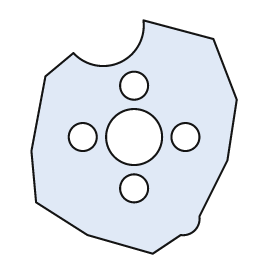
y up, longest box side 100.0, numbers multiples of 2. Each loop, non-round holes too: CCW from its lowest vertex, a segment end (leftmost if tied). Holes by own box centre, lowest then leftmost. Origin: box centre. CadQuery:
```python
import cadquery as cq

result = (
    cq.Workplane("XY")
    .moveTo(8.0, -50.0)
    .lineTo(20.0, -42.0)
    .threePointArc((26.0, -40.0), (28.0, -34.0))
    .lineTo(40.0, -10.0)
    .lineTo(44.0, 16.0)
    .lineTo(34.0, 42.0)
    .lineTo(4.0, 50.0)
    .threePointArc((-6.0, 32.0), (-26.0, 36.0))
    .lineTo(-38.0, 26.0)
    .lineTo(-44.0, -6.0)
    .lineTo(-42.0, -28.0)
    .lineTo(-20.0, -42.0)
    .close()
    .moveTo(0.0, -22.0)
    .circle(6.0)
    .moveTo(-22.0, 0.0)
    .circle(6.0)
    .moveTo(0.0, 0.0)
    .circle(12.0)
    .moveTo(22.0, 0.0)
    .circle(6.0)
    .moveTo(0.0, 22.0)
    .circle(6.0)
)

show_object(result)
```